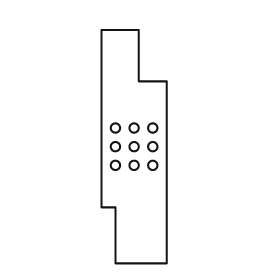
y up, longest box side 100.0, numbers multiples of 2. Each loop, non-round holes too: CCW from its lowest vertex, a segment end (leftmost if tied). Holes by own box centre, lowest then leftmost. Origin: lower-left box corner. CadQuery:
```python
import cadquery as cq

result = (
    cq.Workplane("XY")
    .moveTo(6.0, 0.0)
    .lineTo(28.0, 0.0)
    .lineTo(28.0, 78.0)
    .lineTo(16.0, 78.0)
    .lineTo(16.0, 100.0)
    .lineTo(0.0, 100.0)
    .lineTo(0.0, 24.0)
    .lineTo(6.0, 24.0)
    .close()
    .moveTo(6.0, 42.0)
    .circle(2.0)
    .moveTo(14.0, 42.0)
    .circle(2.0)
    .moveTo(22.0, 42.0)
    .circle(2.0)
    .moveTo(6.0, 50.0)
    .circle(2.0)
    .moveTo(14.0, 50.0)
    .circle(2.0)
    .moveTo(22.0, 50.0)
    .circle(2.0)
    .moveTo(6.0, 58.0)
    .circle(2.0)
    .moveTo(14.0, 58.0)
    .circle(2.0)
    .moveTo(22.0, 58.0)
    .circle(2.0)
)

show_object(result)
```